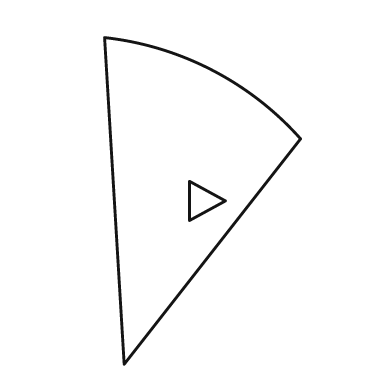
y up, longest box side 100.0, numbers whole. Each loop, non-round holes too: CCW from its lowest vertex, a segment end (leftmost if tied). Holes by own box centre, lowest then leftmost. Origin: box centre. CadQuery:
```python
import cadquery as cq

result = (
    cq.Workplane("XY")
    .moveTo(-24.0, -50.0)
    .lineTo(30.0, 19.0)
    .threePointArc((3.0, 40.0), (-30.0, 50.0))
    .close()
    .moveTo(-4.0, -6.0)
    .lineTo(7.0, 0.0)
    .lineTo(-4.0, 6.0)
    .close()
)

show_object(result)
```